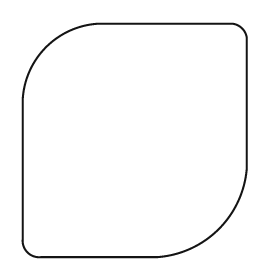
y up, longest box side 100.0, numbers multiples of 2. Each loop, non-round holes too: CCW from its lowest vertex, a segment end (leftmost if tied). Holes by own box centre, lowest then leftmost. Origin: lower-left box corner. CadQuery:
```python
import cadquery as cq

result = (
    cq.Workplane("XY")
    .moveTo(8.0, 0.0)
    .lineTo(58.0, 0.0)
    .threePointArc((84.0, 12.0), (96.0, 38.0))
    .lineTo(96.0, 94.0)
    .threePointArc((94.0, 98.0), (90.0, 100.0))
    .lineTo(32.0, 100.0)
    .threePointArc((10.0, 90.0), (0.0, 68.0))
    .lineTo(0.0, 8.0)
    .threePointArc((2.0, 2.0), (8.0, 0.0))
    .close()
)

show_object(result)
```